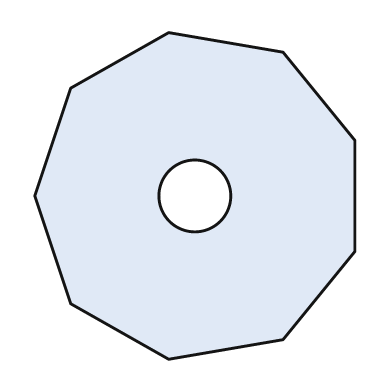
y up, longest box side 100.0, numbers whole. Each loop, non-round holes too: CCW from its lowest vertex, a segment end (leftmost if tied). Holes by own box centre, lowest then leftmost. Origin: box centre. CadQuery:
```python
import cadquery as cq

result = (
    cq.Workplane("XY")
    .moveTo(-8.0, -50.0)
    .lineTo(27.0, -44.0)
    .lineTo(49.0, -17.0)
    .lineTo(49.0, 17.0)
    .lineTo(27.0, 44.0)
    .lineTo(-8.0, 50.0)
    .lineTo(-38.0, 33.0)
    .lineTo(-49.0, 0.0)
    .lineTo(-38.0, -33.0)
    .close()
    .moveTo(0.0, 0.0)
    .circle(11.0)
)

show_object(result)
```